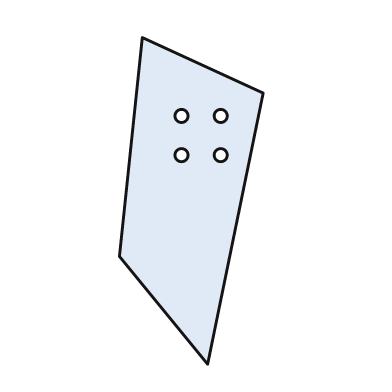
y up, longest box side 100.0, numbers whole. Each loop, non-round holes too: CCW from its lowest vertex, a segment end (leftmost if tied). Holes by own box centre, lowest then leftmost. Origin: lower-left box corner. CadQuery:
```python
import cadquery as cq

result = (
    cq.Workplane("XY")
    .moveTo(27.0, 0.0)
    .lineTo(44.0, 83.0)
    .lineTo(7.0, 100.0)
    .lineTo(0.0, 33.0)
    .close()
    .moveTo(19.0, 64.0)
    .circle(2.0)
    .moveTo(31.0, 64.0)
    .circle(2.0)
    .moveTo(19.0, 76.0)
    .circle(2.0)
    .moveTo(31.0, 76.0)
    .circle(2.0)
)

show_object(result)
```